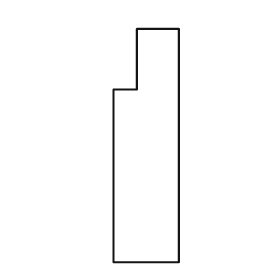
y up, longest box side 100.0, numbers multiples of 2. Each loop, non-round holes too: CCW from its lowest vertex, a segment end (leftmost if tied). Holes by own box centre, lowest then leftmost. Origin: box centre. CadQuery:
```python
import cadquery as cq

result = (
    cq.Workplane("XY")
    .moveTo(-14.0, -50.0)
    .lineTo(14.0, -50.0)
    .lineTo(14.0, 50.0)
    .lineTo(-4.0, 50.0)
    .lineTo(-4.0, 24.0)
    .lineTo(-14.0, 24.0)
    .close()
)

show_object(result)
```